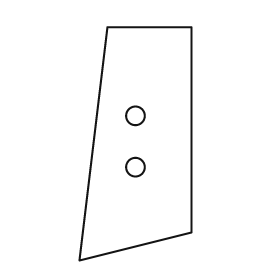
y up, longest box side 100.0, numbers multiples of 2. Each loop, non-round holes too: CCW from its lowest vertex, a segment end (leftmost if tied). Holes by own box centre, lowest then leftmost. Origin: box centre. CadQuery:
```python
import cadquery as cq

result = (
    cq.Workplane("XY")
    .moveTo(-24.0, -50.0)
    .lineTo(24.0, -38.0)
    .lineTo(24.0, 50.0)
    .lineTo(-12.0, 50.0)
    .close()
    .moveTo(0.0, -10.0)
    .circle(4.0)
    .moveTo(0.0, 12.0)
    .circle(4.0)
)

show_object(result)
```